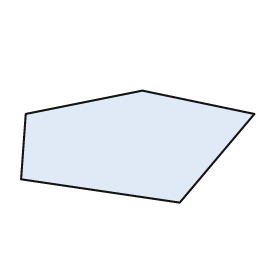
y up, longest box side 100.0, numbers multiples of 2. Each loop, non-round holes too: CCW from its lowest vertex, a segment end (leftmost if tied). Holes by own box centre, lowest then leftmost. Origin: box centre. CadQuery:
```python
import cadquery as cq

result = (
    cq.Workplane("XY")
    .moveTo(18.0, -24.0)
    .lineTo(50.0, 14.0)
    .lineTo(2.0, 24.0)
    .lineTo(-48.0, 14.0)
    .lineTo(-50.0, -14.0)
    .close()
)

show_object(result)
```